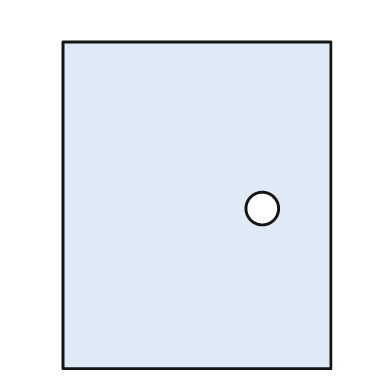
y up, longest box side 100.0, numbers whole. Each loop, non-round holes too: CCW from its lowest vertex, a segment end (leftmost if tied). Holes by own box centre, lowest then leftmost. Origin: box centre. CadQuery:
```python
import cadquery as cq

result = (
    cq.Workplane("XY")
    .moveTo(-41.0, -50.0)
    .lineTo(41.0, -50.0)
    .lineTo(41.0, 50.0)
    .lineTo(-41.0, 50.0)
    .close()
    .moveTo(20.0, -1.0)
    .circle(5.0)
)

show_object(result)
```